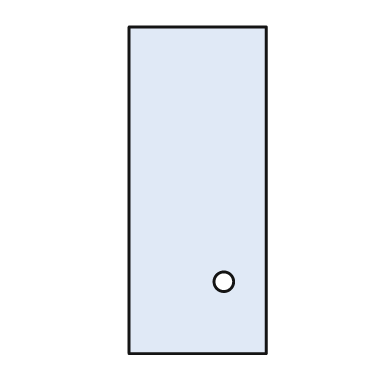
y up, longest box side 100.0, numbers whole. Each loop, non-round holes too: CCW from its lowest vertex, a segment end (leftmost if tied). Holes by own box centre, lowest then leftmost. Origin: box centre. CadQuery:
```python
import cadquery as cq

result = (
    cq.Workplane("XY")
    .moveTo(-21.0, -50.0)
    .lineTo(21.0, -50.0)
    .lineTo(21.0, 50.0)
    .lineTo(-21.0, 50.0)
    .close()
    .moveTo(8.0, -28.0)
    .circle(3.0)
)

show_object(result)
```